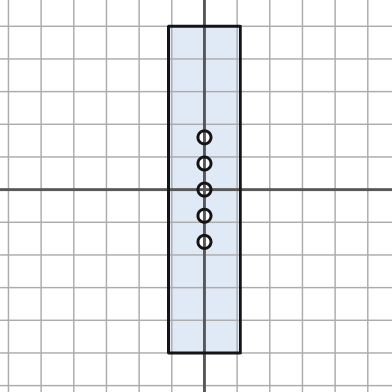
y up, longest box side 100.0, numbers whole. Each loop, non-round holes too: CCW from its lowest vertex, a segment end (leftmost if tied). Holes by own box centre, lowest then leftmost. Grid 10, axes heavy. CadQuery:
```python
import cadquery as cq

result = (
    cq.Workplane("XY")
    .moveTo(-11.0, -50.0)
    .lineTo(11.0, -50.0)
    .lineTo(11.0, 50.0)
    .lineTo(-11.0, 50.0)
    .close()
    .moveTo(0.0, -16.0)
    .circle(2.0)
    .moveTo(0.0, -8.0)
    .circle(2.0)
    .moveTo(0.0, 0.0)
    .circle(2.0)
    .moveTo(0.0, 8.0)
    .circle(2.0)
    .moveTo(0.0, 16.0)
    .circle(2.0)
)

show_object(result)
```